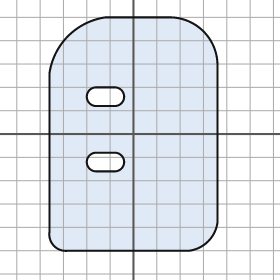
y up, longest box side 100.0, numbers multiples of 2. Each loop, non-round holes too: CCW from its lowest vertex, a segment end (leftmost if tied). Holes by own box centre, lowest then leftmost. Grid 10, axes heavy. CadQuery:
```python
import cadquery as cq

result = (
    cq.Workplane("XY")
    .moveTo(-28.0, -50.0)
    .lineTo(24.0, -50.0)
    .threePointArc((32.0, -46.0), (36.0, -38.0))
    .lineTo(36.0, 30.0)
    .threePointArc((30.0, 44.0), (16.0, 50.0))
    .lineTo(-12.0, 50.0)
    .threePointArc((-28.0, 42.0), (-36.0, 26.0))
    .lineTo(-36.0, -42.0)
    .threePointArc((-34.0, -48.0), (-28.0, -50.0))
    .close()
    .moveTo(-16.0, -16.0)
    .lineTo(-8.0, -16.0)
    .threePointArc((-4.0, -12.0), (-8.0, -8.0))
    .lineTo(-16.0, -8.0)
    .threePointArc((-20.0, -12.0), (-16.0, -16.0))
    .close()
    .moveTo(-16.0, 12.0)
    .lineTo(-8.0, 12.0)
    .threePointArc((-4.0, 16.0), (-8.0, 20.0))
    .lineTo(-16.0, 20.0)
    .threePointArc((-20.0, 16.0), (-16.0, 12.0))
    .close()
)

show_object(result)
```